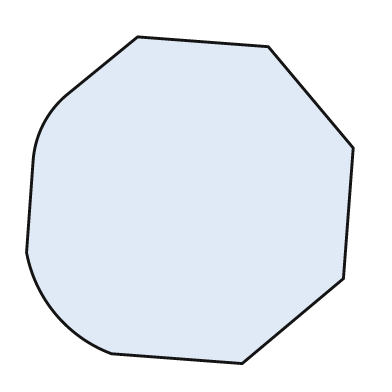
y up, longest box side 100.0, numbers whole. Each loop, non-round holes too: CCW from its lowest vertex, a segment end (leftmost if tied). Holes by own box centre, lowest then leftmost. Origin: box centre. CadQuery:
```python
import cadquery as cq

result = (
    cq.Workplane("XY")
    .moveTo(16.0, -50.0)
    .lineTo(47.0, -24.0)
    .lineTo(50.0, 16.0)
    .lineTo(24.0, 47.0)
    .lineTo(-16.0, 50.0)
    .lineTo(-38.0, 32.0)
    .threePointArc((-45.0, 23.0), (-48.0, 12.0))
    .lineTo(-50.0, -16.0)
    .threePointArc((-41.0, -35.0), (-24.0, -47.0))
    .close()
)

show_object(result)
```